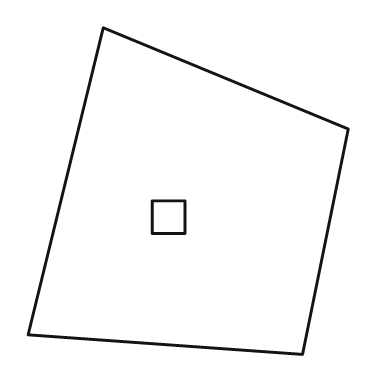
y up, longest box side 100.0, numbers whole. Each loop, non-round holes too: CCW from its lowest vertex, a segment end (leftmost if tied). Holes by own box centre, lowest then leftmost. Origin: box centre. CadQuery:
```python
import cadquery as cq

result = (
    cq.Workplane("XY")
    .moveTo(35.0, -50.0)
    .lineTo(49.0, 19.0)
    .lineTo(-26.0, 50.0)
    .lineTo(-49.0, -44.0)
    .close()
    .moveTo(-11.0, -13.0)
    .lineTo(-1.0, -13.0)
    .lineTo(-1.0, -3.0)
    .lineTo(-11.0, -3.0)
    .close()
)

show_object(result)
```